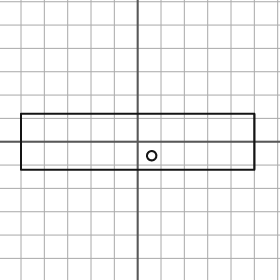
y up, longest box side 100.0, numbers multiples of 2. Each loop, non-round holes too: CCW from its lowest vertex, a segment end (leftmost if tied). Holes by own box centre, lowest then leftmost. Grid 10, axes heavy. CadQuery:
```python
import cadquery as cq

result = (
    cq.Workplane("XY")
    .moveTo(-50.0, -12.0)
    .lineTo(50.0, -12.0)
    .lineTo(50.0, 12.0)
    .lineTo(-50.0, 12.0)
    .close()
    .moveTo(6.0, -6.0)
    .circle(2.0)
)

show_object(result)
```